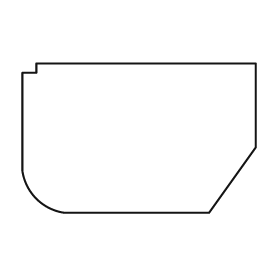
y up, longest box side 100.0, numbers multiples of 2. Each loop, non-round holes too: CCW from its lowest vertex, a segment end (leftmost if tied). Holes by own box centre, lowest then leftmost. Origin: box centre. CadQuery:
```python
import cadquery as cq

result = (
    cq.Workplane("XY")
    .moveTo(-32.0, -32.0)
    .lineTo(30.0, -32.0)
    .lineTo(50.0, -4.0)
    .lineTo(50.0, 32.0)
    .lineTo(-44.0, 32.0)
    .lineTo(-44.0, 28.0)
    .lineTo(-50.0, 28.0)
    .lineTo(-50.0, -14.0)
    .threePointArc((-44.0, -26.0), (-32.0, -32.0))
    .close()
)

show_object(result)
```